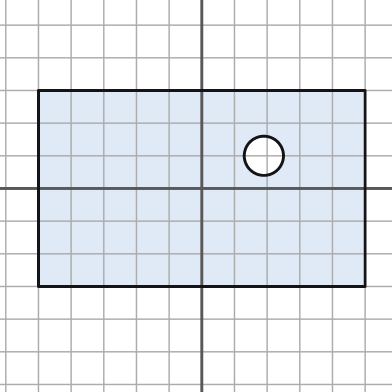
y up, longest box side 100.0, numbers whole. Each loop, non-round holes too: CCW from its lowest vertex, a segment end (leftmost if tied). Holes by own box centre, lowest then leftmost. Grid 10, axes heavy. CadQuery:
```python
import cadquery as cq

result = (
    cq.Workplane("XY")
    .moveTo(-50.0, -30.0)
    .lineTo(50.0, -30.0)
    .lineTo(50.0, 30.0)
    .lineTo(-50.0, 30.0)
    .close()
    .moveTo(19.0, 10.0)
    .circle(6.0)
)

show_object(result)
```